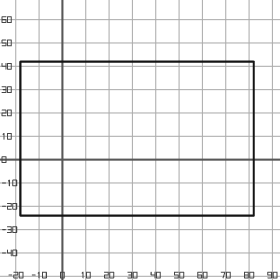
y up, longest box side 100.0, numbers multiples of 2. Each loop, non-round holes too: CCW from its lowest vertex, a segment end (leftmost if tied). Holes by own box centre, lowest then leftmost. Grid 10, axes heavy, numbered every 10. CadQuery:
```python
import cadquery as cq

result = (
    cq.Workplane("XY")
    .moveTo(-18.0, -24.0)
    .lineTo(82.0, -24.0)
    .lineTo(82.0, 42.0)
    .lineTo(-18.0, 42.0)
    .close()
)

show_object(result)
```